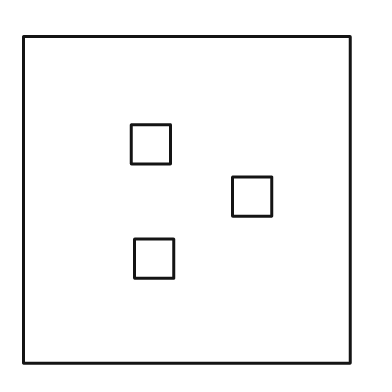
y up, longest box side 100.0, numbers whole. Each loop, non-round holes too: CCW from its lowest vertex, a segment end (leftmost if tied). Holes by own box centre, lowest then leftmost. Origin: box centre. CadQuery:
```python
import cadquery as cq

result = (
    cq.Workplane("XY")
    .moveTo(-50.0, -50.0)
    .lineTo(50.0, -50.0)
    .lineTo(50.0, 50.0)
    .lineTo(-50.0, 50.0)
    .close()
    .moveTo(-16.0, -24.0)
    .lineTo(-4.0, -24.0)
    .lineTo(-4.0, -12.0)
    .lineTo(-16.0, -12.0)
    .close()
    .moveTo(14.0, -5.0)
    .lineTo(26.0, -5.0)
    .lineTo(26.0, 7.0)
    .lineTo(14.0, 7.0)
    .close()
    .moveTo(-17.0, 11.0)
    .lineTo(-5.0, 11.0)
    .lineTo(-5.0, 23.0)
    .lineTo(-17.0, 23.0)
    .close()
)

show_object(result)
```